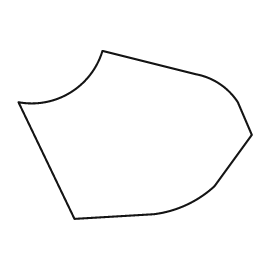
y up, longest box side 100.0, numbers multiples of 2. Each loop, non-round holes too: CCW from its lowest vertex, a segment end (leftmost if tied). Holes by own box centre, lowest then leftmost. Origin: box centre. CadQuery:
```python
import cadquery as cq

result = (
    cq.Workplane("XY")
    .moveTo(-26.0, -36.0)
    .lineTo(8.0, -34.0)
    .threePointArc((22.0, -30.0), (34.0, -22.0))
    .lineTo(50.0, 0.0)
    .lineTo(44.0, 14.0)
    .threePointArc((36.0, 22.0), (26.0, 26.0))
    .lineTo(-14.0, 36.0)
    .threePointArc((-28.0, 18.0), (-50.0, 14.0))
    .close()
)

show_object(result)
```